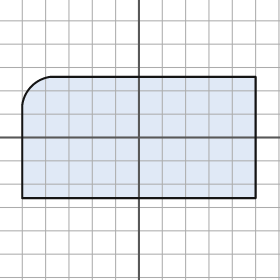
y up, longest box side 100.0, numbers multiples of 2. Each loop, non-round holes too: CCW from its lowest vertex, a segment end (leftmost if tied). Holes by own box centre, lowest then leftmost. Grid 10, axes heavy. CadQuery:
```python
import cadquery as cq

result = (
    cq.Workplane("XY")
    .moveTo(-50.0, -26.0)
    .lineTo(50.0, -26.0)
    .lineTo(50.0, 26.0)
    .lineTo(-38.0, 26.0)
    .threePointArc((-46.0, 22.0), (-50.0, 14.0))
    .close()
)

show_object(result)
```